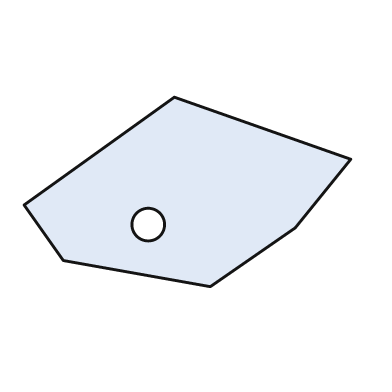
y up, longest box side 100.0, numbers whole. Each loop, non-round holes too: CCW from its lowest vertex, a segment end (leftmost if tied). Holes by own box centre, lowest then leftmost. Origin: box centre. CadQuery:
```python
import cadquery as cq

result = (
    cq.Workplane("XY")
    .moveTo(7.0, -29.0)
    .lineTo(33.0, -11.0)
    .lineTo(50.0, 10.0)
    .lineTo(-4.0, 29.0)
    .lineTo(-50.0, -4.0)
    .lineTo(-38.0, -21.0)
    .close()
    .moveTo(-12.0, -10.0)
    .circle(5.0)
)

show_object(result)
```